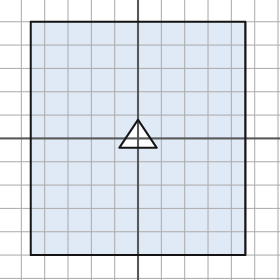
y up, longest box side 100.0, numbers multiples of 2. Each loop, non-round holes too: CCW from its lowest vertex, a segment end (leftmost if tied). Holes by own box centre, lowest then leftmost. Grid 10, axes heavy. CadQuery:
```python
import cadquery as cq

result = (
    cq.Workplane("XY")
    .moveTo(-46.0, -50.0)
    .lineTo(46.0, -50.0)
    .lineTo(46.0, 50.0)
    .lineTo(-46.0, 50.0)
    .close()
    .moveTo(-8.0, -4.0)
    .lineTo(8.0, -4.0)
    .lineTo(0.0, 8.0)
    .close()
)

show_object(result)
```